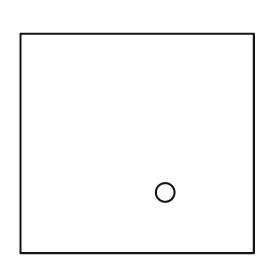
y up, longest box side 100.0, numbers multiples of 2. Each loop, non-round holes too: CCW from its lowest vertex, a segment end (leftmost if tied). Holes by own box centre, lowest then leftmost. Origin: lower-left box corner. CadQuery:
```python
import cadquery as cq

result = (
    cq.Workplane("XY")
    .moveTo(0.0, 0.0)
    .lineTo(100.0, 0.0)
    .lineTo(100.0, 94.0)
    .lineTo(0.0, 94.0)
    .close()
    .moveTo(62.0, 26.0)
    .circle(4.0)
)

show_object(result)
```